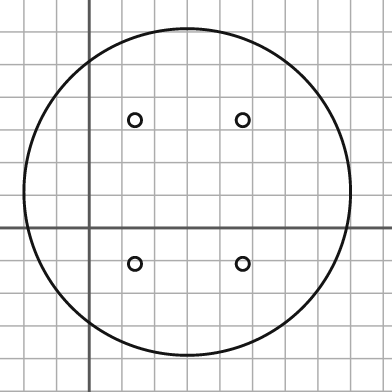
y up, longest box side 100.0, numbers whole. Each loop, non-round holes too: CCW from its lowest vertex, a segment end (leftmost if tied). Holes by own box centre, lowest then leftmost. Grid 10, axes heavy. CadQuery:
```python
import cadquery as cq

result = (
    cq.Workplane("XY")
    .moveTo(30.0, 11.0)
    .circle(50.0)
    .moveTo(14.0, -11.0)
    .circle(2.0)
    .moveTo(47.0, -11.0)
    .circle(2.0)
    .moveTo(14.0, 33.0)
    .circle(2.0)
    .moveTo(47.0, 33.0)
    .circle(2.0)
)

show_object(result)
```